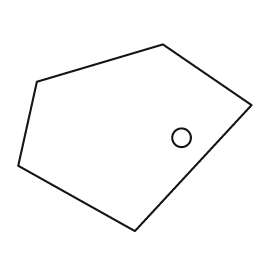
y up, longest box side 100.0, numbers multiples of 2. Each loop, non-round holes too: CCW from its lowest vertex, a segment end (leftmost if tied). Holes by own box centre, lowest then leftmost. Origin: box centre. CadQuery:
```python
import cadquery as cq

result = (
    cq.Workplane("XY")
    .moveTo(0.0, -40.0)
    .lineTo(50.0, 14.0)
    .lineTo(12.0, 40.0)
    .lineTo(-42.0, 24.0)
    .lineTo(-50.0, -12.0)
    .close()
    .moveTo(20.0, 0.0)
    .circle(4.0)
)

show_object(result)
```